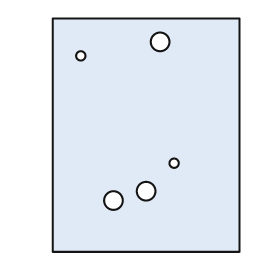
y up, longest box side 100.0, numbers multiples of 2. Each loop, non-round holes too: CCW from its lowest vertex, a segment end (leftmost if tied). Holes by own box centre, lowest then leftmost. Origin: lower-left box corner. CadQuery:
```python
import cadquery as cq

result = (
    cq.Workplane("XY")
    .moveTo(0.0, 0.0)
    .lineTo(80.0, 0.0)
    .lineTo(80.0, 100.0)
    .lineTo(0.0, 100.0)
    .close()
    .moveTo(26.0, 22.0)
    .circle(4.0)
    .moveTo(40.0, 26.0)
    .circle(4.0)
    .moveTo(52.0, 38.0)
    .circle(2.0)
    .moveTo(12.0, 84.0)
    .circle(2.0)
    .moveTo(46.0, 90.0)
    .circle(4.0)
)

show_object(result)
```